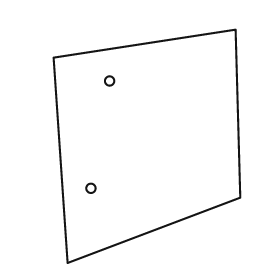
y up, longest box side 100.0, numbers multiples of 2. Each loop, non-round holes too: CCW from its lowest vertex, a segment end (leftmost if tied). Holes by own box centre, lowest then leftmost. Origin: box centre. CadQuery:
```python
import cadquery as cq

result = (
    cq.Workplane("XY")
    .moveTo(-34.0, -50.0)
    .lineTo(40.0, -22.0)
    .lineTo(38.0, 50.0)
    .lineTo(-40.0, 38.0)
    .close()
    .moveTo(-24.0, -18.0)
    .circle(2.0)
    .moveTo(-16.0, 28.0)
    .circle(2.0)
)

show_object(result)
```